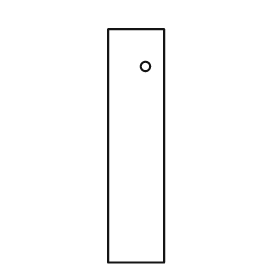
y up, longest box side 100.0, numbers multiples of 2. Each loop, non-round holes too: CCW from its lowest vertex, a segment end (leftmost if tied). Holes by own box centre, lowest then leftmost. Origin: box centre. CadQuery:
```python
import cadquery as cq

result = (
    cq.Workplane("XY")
    .moveTo(-12.0, -50.0)
    .lineTo(12.0, -50.0)
    .lineTo(12.0, 50.0)
    .lineTo(-12.0, 50.0)
    .close()
    .moveTo(4.0, 34.0)
    .circle(2.0)
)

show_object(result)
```